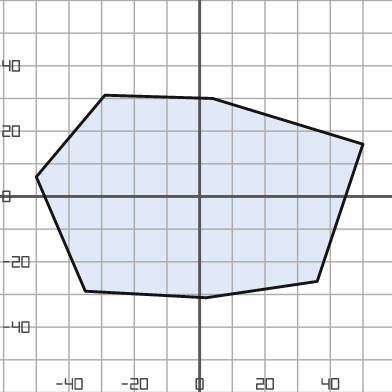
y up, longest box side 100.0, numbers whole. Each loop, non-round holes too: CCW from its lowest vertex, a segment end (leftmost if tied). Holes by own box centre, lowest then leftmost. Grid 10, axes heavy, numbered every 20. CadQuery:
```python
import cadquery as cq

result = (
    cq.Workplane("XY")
    .moveTo(2.0, -31.0)
    .lineTo(36.0, -26.0)
    .lineTo(50.0, 16.0)
    .lineTo(4.0, 30.0)
    .lineTo(-29.0, 31.0)
    .lineTo(-50.0, 6.0)
    .lineTo(-35.0, -29.0)
    .close()
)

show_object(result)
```